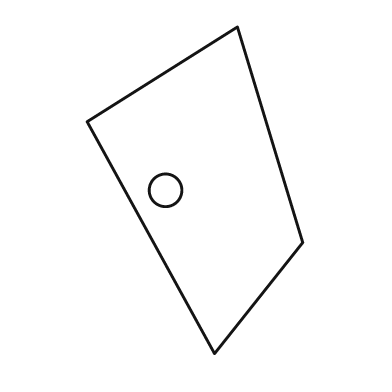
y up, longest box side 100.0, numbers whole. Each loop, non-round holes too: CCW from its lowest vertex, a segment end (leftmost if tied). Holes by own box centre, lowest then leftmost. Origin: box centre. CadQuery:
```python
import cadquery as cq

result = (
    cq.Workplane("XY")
    .moveTo(6.0, -50.0)
    .lineTo(33.0, -16.0)
    .lineTo(13.0, 50.0)
    .lineTo(-33.0, 21.0)
    .close()
    .moveTo(-9.0, 0.0)
    .circle(5.0)
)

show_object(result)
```